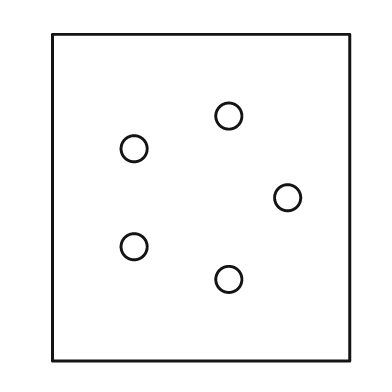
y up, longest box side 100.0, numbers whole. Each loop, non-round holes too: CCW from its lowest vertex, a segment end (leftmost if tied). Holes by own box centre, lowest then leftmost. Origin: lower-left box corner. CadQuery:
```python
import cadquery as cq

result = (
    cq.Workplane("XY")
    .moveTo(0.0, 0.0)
    .lineTo(91.0, 0.0)
    .lineTo(91.0, 100.0)
    .lineTo(0.0, 100.0)
    .close()
    .moveTo(54.0, 25.0)
    .circle(4.0)
    .moveTo(25.0, 35.0)
    .circle(4.0)
    .moveTo(72.0, 50.0)
    .circle(4.0)
    .moveTo(25.0, 65.0)
    .circle(4.0)
    .moveTo(54.0, 75.0)
    .circle(4.0)
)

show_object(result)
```